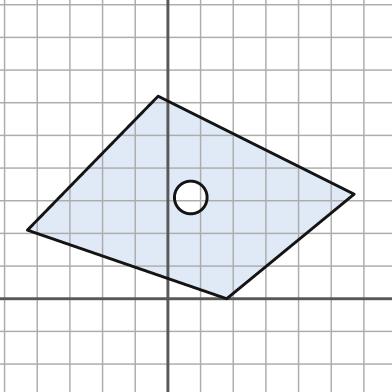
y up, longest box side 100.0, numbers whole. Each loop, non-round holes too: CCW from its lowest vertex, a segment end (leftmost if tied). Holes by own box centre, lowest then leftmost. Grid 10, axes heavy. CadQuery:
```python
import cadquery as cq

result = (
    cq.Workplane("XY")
    .moveTo(18.0, 0.0)
    .lineTo(57.0, 32.0)
    .lineTo(-3.0, 62.0)
    .lineTo(-43.0, 21.0)
    .close()
    .moveTo(7.0, 31.0)
    .circle(5.0)
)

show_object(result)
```